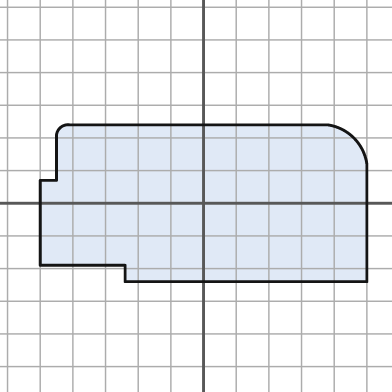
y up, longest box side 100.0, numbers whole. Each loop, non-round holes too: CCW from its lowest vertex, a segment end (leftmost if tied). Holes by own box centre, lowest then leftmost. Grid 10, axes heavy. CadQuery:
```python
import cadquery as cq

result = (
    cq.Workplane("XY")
    .moveTo(-24.0, -24.0)
    .lineTo(50.0, -24.0)
    .lineTo(50.0, 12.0)
    .threePointArc((46.0, 20.0), (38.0, 24.0))
    .lineTo(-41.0, 24.0)
    .threePointArc((-44.0, 23.0), (-45.0, 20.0))
    .lineTo(-45.0, 7.0)
    .lineTo(-50.0, 7.0)
    .lineTo(-50.0, -19.0)
    .lineTo(-24.0, -19.0)
    .close()
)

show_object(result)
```